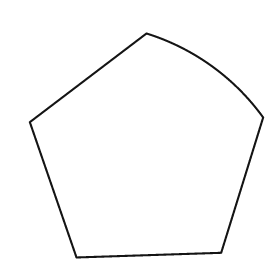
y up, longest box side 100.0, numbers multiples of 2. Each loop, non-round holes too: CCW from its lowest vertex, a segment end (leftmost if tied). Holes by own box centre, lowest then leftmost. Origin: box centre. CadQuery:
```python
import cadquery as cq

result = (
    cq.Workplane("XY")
    .moveTo(-30.0, -48.0)
    .lineTo(32.0, -46.0)
    .lineTo(50.0, 12.0)
    .threePointArc((28.0, 34.0), (0.0, 48.0))
    .lineTo(-50.0, 10.0)
    .close()
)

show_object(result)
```